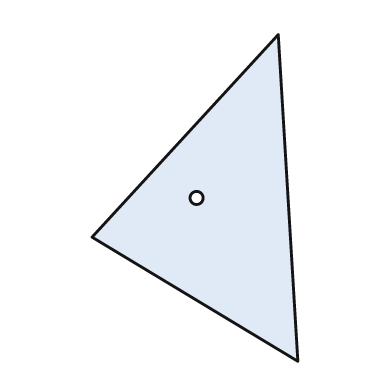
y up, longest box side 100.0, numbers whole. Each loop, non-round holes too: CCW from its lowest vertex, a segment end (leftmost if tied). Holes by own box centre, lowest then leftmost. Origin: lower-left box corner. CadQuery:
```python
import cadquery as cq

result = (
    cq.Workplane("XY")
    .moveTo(63.0, 0.0)
    .lineTo(57.0, 100.0)
    .lineTo(0.0, 38.0)
    .close()
    .moveTo(32.0, 50.0)
    .circle(2.0)
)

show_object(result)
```